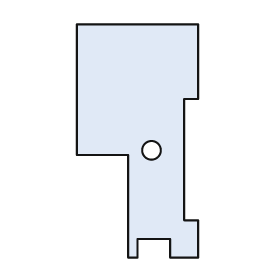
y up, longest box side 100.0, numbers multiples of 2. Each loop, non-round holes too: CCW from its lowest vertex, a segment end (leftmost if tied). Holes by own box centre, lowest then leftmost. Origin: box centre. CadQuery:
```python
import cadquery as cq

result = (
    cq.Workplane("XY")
    .moveTo(-4.0, -50.0)
    .lineTo(0.0, -50.0)
    .lineTo(0.0, -42.0)
    .lineTo(14.0, -42.0)
    .lineTo(14.0, -50.0)
    .lineTo(26.0, -50.0)
    .lineTo(26.0, -34.0)
    .lineTo(20.0, -34.0)
    .lineTo(20.0, 18.0)
    .lineTo(26.0, 18.0)
    .lineTo(26.0, 50.0)
    .lineTo(-26.0, 50.0)
    .lineTo(-26.0, -6.0)
    .lineTo(-4.0, -6.0)
    .close()
    .moveTo(6.0, -4.0)
    .circle(4.0)
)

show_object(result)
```